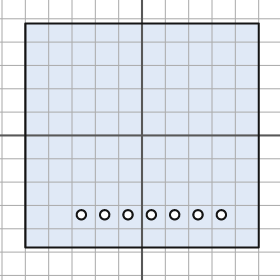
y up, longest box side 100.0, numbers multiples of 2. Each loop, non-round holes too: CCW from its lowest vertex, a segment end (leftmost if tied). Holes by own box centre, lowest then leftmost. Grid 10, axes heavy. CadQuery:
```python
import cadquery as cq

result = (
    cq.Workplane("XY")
    .moveTo(-50.0, -48.0)
    .lineTo(50.0, -48.0)
    .lineTo(50.0, 48.0)
    .lineTo(-50.0, 48.0)
    .close()
    .moveTo(-26.0, -34.0)
    .circle(2.0)
    .moveTo(-16.0, -34.0)
    .circle(2.0)
    .moveTo(-6.0, -34.0)
    .circle(2.0)
    .moveTo(4.0, -34.0)
    .circle(2.0)
    .moveTo(14.0, -34.0)
    .circle(2.0)
    .moveTo(24.0, -34.0)
    .circle(2.0)
    .moveTo(34.0, -34.0)
    .circle(2.0)
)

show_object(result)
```